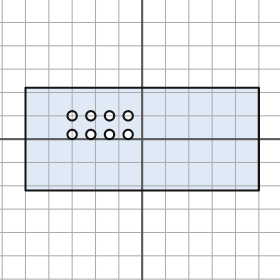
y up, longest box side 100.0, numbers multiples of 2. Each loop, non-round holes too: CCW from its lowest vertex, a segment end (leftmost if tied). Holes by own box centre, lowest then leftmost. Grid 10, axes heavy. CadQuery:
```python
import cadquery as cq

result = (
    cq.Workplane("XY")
    .moveTo(-50.0, -22.0)
    .lineTo(50.0, -22.0)
    .lineTo(50.0, 22.0)
    .lineTo(-50.0, 22.0)
    .close()
    .moveTo(-30.0, 2.0)
    .circle(2.0)
    .moveTo(-22.0, 2.0)
    .circle(2.0)
    .moveTo(-14.0, 2.0)
    .circle(2.0)
    .moveTo(-6.0, 2.0)
    .circle(2.0)
    .moveTo(-30.0, 10.0)
    .circle(2.0)
    .moveTo(-22.0, 10.0)
    .circle(2.0)
    .moveTo(-14.0, 10.0)
    .circle(2.0)
    .moveTo(-6.0, 10.0)
    .circle(2.0)
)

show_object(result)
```